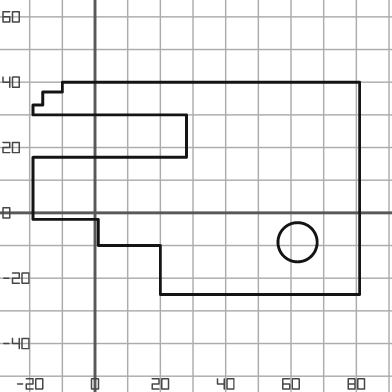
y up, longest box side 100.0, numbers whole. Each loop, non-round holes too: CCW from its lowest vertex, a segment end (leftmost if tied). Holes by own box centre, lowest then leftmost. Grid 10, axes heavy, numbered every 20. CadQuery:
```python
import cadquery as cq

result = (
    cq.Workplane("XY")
    .moveTo(20.0, -25.0)
    .lineTo(81.0, -25.0)
    .lineTo(81.0, 40.0)
    .lineTo(-10.0, 40.0)
    .lineTo(-10.0, 37.0)
    .lineTo(-16.0, 37.0)
    .lineTo(-16.0, 33.0)
    .lineTo(-19.0, 33.0)
    .lineTo(-19.0, 30.0)
    .lineTo(28.0, 30.0)
    .lineTo(28.0, 17.0)
    .lineTo(-19.0, 17.0)
    .lineTo(-19.0, -2.0)
    .lineTo(1.0, -2.0)
    .lineTo(1.0, -10.0)
    .lineTo(20.0, -10.0)
    .close()
    .moveTo(62.0, -9.0)
    .circle(6.0)
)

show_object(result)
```